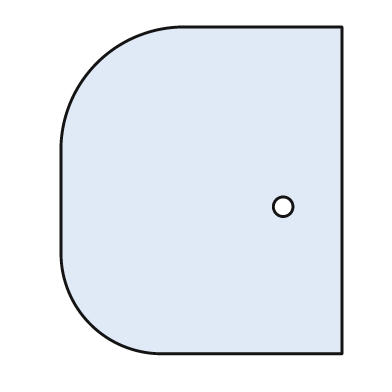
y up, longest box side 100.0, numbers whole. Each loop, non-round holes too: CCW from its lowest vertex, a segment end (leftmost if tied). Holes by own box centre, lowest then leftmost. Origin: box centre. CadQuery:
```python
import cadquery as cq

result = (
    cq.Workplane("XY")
    .moveTo(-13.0, -50.0)
    .lineTo(43.0, -50.0)
    .lineTo(43.0, 50.0)
    .lineTo(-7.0, 50.0)
    .threePointArc((-32.0, 39.0), (-43.0, 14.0))
    .lineTo(-43.0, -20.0)
    .threePointArc((-34.0, -41.0), (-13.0, -50.0))
    .close()
    .moveTo(25.0, -5.0)
    .circle(3.0)
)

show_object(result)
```